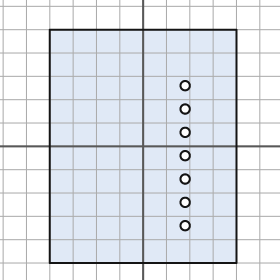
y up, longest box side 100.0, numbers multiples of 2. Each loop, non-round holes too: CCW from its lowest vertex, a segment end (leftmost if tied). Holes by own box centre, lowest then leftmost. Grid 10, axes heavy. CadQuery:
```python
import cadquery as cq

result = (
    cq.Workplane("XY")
    .moveTo(-40.0, -50.0)
    .lineTo(40.0, -50.0)
    .lineTo(40.0, 50.0)
    .lineTo(-40.0, 50.0)
    .close()
    .moveTo(18.0, -34.0)
    .circle(2.0)
    .moveTo(18.0, -24.0)
    .circle(2.0)
    .moveTo(18.0, -14.0)
    .circle(2.0)
    .moveTo(18.0, -4.0)
    .circle(2.0)
    .moveTo(18.0, 6.0)
    .circle(2.0)
    .moveTo(18.0, 16.0)
    .circle(2.0)
    .moveTo(18.0, 26.0)
    .circle(2.0)
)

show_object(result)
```